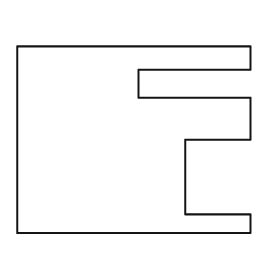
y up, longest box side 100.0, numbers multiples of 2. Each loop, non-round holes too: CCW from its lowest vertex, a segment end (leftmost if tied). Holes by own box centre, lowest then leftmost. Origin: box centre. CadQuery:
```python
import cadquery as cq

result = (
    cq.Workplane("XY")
    .moveTo(-50.0, -40.0)
    .lineTo(50.0, -40.0)
    .lineTo(50.0, -32.0)
    .lineTo(22.0, -32.0)
    .lineTo(22.0, 0.0)
    .lineTo(50.0, 0.0)
    .lineTo(50.0, 18.0)
    .lineTo(2.0, 18.0)
    .lineTo(2.0, 30.0)
    .lineTo(50.0, 30.0)
    .lineTo(50.0, 40.0)
    .lineTo(-50.0, 40.0)
    .close()
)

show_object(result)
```